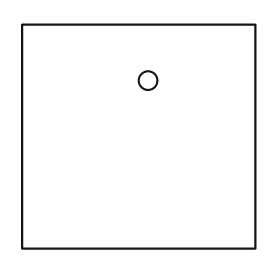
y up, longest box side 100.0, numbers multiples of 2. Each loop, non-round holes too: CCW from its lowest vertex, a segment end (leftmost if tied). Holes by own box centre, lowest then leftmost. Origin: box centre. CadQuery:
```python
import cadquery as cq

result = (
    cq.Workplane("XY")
    .moveTo(-50.0, -48.0)
    .lineTo(50.0, -48.0)
    .lineTo(50.0, 48.0)
    .lineTo(-50.0, 48.0)
    .close()
    .moveTo(4.0, 24.0)
    .circle(4.0)
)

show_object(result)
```